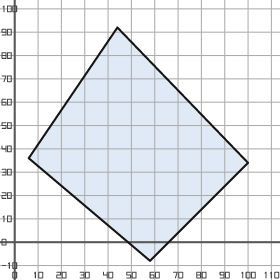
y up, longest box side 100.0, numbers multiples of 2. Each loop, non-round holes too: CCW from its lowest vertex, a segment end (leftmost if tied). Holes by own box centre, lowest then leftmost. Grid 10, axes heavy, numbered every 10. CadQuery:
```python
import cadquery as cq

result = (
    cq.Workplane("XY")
    .moveTo(58.0, -8.0)
    .lineTo(100.0, 34.0)
    .lineTo(44.0, 92.0)
    .lineTo(6.0, 36.0)
    .close()
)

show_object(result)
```